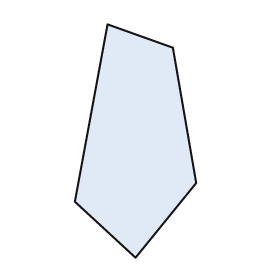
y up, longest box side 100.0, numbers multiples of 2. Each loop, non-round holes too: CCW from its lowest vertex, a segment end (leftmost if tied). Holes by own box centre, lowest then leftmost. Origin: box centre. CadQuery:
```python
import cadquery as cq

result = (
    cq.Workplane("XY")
    .moveTo(0.0, -50.0)
    .lineTo(26.0, -18.0)
    .lineTo(16.0, 40.0)
    .lineTo(-12.0, 50.0)
    .lineTo(-26.0, -26.0)
    .close()
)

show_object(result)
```